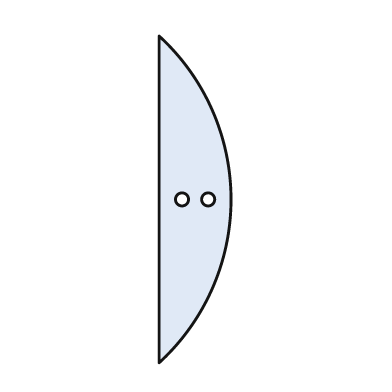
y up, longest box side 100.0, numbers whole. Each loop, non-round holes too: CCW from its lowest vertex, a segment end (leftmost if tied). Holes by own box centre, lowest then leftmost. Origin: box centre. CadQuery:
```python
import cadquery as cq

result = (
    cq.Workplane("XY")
    .moveTo(-11.0, -50.0)
    .threePointArc((11.0, 0.0), (-11.0, 50.0))
    .close()
    .moveTo(-4.0, 0.0)
    .circle(2.0)
    .moveTo(4.0, 0.0)
    .circle(2.0)
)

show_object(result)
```